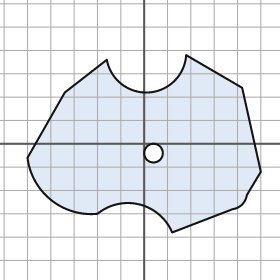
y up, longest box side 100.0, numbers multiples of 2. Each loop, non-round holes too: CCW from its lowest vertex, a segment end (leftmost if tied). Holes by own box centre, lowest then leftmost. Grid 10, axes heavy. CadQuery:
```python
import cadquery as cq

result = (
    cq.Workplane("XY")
    .moveTo(12.0, -38.0)
    .lineTo(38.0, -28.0)
    .threePointArc((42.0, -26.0), (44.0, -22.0))
    .lineTo(50.0, -12.0)
    .lineTo(42.0, 24.0)
    .lineTo(18.0, 38.0)
    .threePointArc((2.0, 22.0), (-16.0, 36.0))
    .lineTo(-34.0, 22.0)
    .lineTo(-50.0, -6.0)
    .threePointArc((-40.0, -24.0), (-20.0, -30.0))
    .threePointArc((-2.0, -26.0), (12.0, -38.0))
    .close()
    .moveTo(4.0, -4.0)
    .circle(4.0)
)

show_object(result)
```